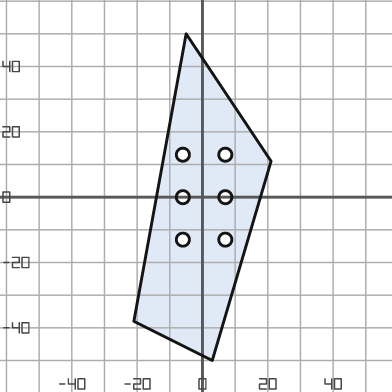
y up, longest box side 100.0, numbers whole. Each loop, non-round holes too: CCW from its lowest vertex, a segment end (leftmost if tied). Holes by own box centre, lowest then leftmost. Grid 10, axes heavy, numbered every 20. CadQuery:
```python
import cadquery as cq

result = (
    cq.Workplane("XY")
    .moveTo(3.0, -50.0)
    .lineTo(21.0, 11.0)
    .lineTo(-5.0, 50.0)
    .lineTo(-21.0, -38.0)
    .close()
    .moveTo(-6.0, -13.0)
    .circle(2.0)
    .moveTo(7.0, -13.0)
    .circle(2.0)
    .moveTo(-6.0, 0.0)
    .circle(2.0)
    .moveTo(7.0, 0.0)
    .circle(2.0)
    .moveTo(-6.0, 13.0)
    .circle(2.0)
    .moveTo(7.0, 13.0)
    .circle(2.0)
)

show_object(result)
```